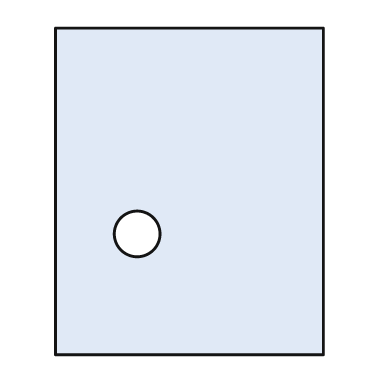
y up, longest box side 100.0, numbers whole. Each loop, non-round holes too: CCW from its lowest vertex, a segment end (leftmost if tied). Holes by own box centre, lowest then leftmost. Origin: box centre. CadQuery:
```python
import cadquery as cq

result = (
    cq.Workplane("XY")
    .moveTo(-41.0, -50.0)
    .lineTo(41.0, -50.0)
    .lineTo(41.0, 50.0)
    .lineTo(-41.0, 50.0)
    .close()
    .moveTo(-16.0, -13.0)
    .circle(7.0)
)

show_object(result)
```